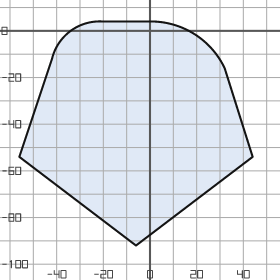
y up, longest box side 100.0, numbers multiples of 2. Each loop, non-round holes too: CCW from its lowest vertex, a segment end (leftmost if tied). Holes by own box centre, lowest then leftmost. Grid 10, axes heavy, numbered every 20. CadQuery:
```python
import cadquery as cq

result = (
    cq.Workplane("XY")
    .moveTo(-6.0, -92.0)
    .lineTo(44.0, -54.0)
    .lineTo(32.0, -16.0)
    .threePointArc((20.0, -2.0), (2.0, 4.0))
    .lineTo(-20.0, 4.0)
    .threePointArc((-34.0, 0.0), (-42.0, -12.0))
    .lineTo(-56.0, -54.0)
    .close()
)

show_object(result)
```